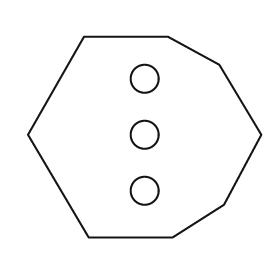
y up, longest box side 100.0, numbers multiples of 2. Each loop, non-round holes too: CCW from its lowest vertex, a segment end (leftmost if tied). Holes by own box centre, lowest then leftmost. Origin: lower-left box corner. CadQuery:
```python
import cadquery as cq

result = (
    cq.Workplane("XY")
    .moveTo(26.0, 0.0)
    .lineTo(62.0, 0.0)
    .lineTo(84.0, 14.0)
    .lineTo(100.0, 44.0)
    .lineTo(82.0, 74.0)
    .lineTo(60.0, 86.0)
    .lineTo(24.0, 86.0)
    .lineTo(0.0, 44.0)
    .close()
    .moveTo(50.0, 20.0)
    .circle(6.0)
    .moveTo(50.0, 44.0)
    .circle(6.0)
    .moveTo(50.0, 68.0)
    .circle(6.0)
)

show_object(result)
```